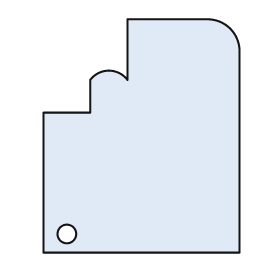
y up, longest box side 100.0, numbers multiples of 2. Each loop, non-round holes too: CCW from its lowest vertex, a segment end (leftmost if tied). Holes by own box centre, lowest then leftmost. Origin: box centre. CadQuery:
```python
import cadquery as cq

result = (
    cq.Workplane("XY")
    .moveTo(-42.0, -50.0)
    .lineTo(42.0, -50.0)
    .lineTo(42.0, 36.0)
    .threePointArc((38.0, 46.0), (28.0, 50.0))
    .lineTo(-6.0, 50.0)
    .lineTo(-6.0, 24.0)
    .threePointArc((-14.0, 28.0), (-22.0, 24.0))
    .lineTo(-22.0, 10.0)
    .lineTo(-42.0, 10.0)
    .close()
    .moveTo(-32.0, -42.0)
    .circle(4.0)
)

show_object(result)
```